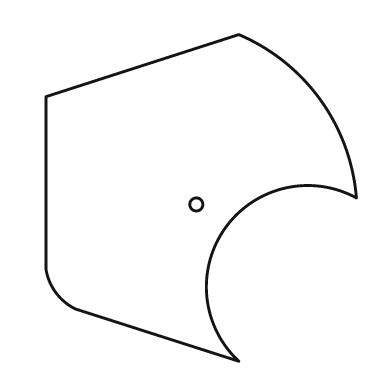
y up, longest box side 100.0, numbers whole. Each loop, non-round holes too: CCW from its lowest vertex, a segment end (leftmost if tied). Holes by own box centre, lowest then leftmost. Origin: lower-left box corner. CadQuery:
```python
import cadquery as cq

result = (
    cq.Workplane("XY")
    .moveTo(59.0, 0.0)
    .threePointArc((55.0, 41.0), (95.0, 50.0))
    .threePointArc((84.0, 80.0), (59.0, 100.0))
    .lineTo(0.0, 81.0)
    .lineTo(0.0, 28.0)
    .threePointArc((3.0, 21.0), (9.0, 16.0))
    .close()
    .moveTo(46.0, 48.0)
    .circle(2.0)
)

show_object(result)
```